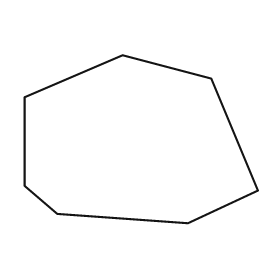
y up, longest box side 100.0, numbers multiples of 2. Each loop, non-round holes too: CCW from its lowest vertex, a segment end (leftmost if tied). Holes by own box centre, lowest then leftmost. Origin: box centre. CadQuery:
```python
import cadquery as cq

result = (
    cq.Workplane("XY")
    .moveTo(20.0, -36.0)
    .lineTo(50.0, -22.0)
    .lineTo(30.0, 26.0)
    .lineTo(-8.0, 36.0)
    .lineTo(-50.0, 18.0)
    .lineTo(-50.0, -20.0)
    .lineTo(-36.0, -32.0)
    .close()
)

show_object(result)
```